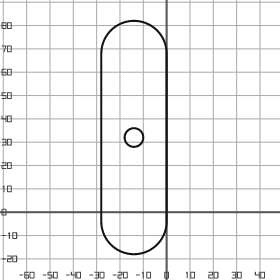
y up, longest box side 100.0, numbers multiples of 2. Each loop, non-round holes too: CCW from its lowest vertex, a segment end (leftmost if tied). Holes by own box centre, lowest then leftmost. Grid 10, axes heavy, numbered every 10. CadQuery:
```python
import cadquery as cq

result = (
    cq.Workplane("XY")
    .moveTo(-28.0, -4.0)
    .threePointArc((-14.0, -18.0), (0.0, -4.0))
    .lineTo(0.0, 68.0)
    .threePointArc((-14.0, 82.0), (-28.0, 68.0))
    .close()
    .moveTo(-14.0, 32.0)
    .circle(4.0)
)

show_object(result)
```